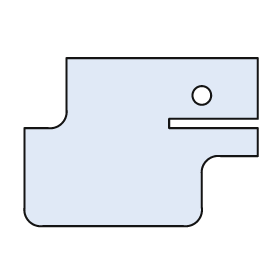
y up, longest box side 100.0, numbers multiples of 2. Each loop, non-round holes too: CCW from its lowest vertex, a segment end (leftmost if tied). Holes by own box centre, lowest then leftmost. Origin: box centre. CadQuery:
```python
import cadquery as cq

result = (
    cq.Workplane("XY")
    .moveTo(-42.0, -36.0)
    .lineTo(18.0, -36.0)
    .threePointArc((24.0, -34.0), (26.0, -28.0))
    .lineTo(26.0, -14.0)
    .threePointArc((28.0, -8.0), (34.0, -6.0))
    .lineTo(50.0, -6.0)
    .lineTo(50.0, 6.0)
    .lineTo(12.0, 6.0)
    .lineTo(12.0, 10.0)
    .lineTo(50.0, 10.0)
    .lineTo(50.0, 36.0)
    .lineTo(-32.0, 36.0)
    .lineTo(-32.0, 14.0)
    .threePointArc((-34.0, 8.0), (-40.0, 6.0))
    .lineTo(-50.0, 6.0)
    .lineTo(-50.0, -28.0)
    .threePointArc((-48.0, -34.0), (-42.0, -36.0))
    .close()
    .moveTo(26.0, 20.0)
    .circle(4.0)
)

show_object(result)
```